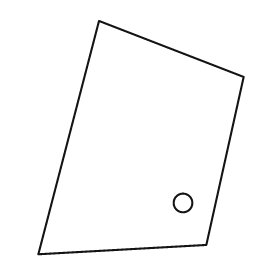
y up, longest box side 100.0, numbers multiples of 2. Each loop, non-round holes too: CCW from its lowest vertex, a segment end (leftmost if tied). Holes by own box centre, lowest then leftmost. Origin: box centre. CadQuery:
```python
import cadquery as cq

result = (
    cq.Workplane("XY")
    .moveTo(-44.0, -50.0)
    .lineTo(28.0, -46.0)
    .lineTo(44.0, 26.0)
    .lineTo(-18.0, 50.0)
    .close()
    .moveTo(18.0, -28.0)
    .circle(4.0)
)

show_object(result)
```